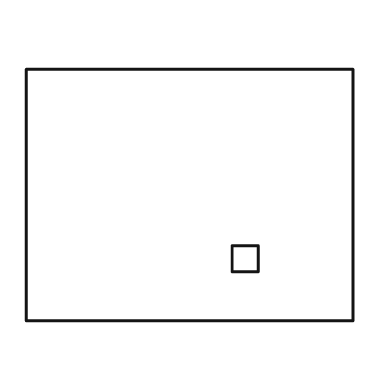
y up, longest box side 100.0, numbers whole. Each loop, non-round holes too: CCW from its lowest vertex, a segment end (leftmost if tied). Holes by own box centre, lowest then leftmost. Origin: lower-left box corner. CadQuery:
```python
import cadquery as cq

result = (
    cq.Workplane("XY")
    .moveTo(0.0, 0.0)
    .lineTo(100.0, 0.0)
    .lineTo(100.0, 77.0)
    .lineTo(0.0, 77.0)
    .close()
    .moveTo(63.0, 15.0)
    .lineTo(71.0, 15.0)
    .lineTo(71.0, 23.0)
    .lineTo(63.0, 23.0)
    .close()
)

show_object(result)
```